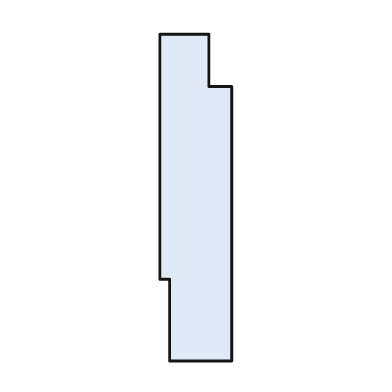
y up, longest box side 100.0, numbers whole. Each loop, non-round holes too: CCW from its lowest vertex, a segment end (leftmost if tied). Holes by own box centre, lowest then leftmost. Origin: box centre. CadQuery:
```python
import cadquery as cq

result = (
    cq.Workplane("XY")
    .moveTo(-8.0, -50.0)
    .lineTo(11.0, -50.0)
    .lineTo(11.0, 34.0)
    .lineTo(4.0, 34.0)
    .lineTo(4.0, 50.0)
    .lineTo(-11.0, 50.0)
    .lineTo(-11.0, -25.0)
    .lineTo(-8.0, -25.0)
    .close()
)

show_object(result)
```